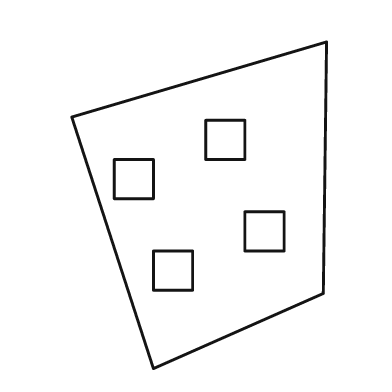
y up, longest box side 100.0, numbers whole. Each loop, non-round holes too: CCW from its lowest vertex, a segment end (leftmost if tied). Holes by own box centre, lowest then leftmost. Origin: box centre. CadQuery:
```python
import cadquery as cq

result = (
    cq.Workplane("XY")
    .moveTo(-14.0, -50.0)
    .lineTo(38.0, -27.0)
    .lineTo(39.0, 50.0)
    .lineTo(-39.0, 27.0)
    .close()
    .moveTo(-14.0, -26.0)
    .lineTo(-2.0, -26.0)
    .lineTo(-2.0, -14.0)
    .lineTo(-14.0, -14.0)
    .close()
    .moveTo(14.0, -14.0)
    .lineTo(26.0, -14.0)
    .lineTo(26.0, -2.0)
    .lineTo(14.0, -2.0)
    .close()
    .moveTo(-26.0, 2.0)
    .lineTo(-14.0, 2.0)
    .lineTo(-14.0, 14.0)
    .lineTo(-26.0, 14.0)
    .close()
    .moveTo(2.0, 14.0)
    .lineTo(14.0, 14.0)
    .lineTo(14.0, 26.0)
    .lineTo(2.0, 26.0)
    .close()
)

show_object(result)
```